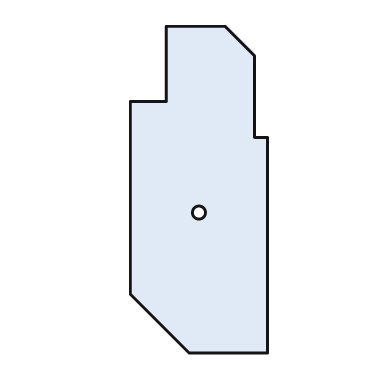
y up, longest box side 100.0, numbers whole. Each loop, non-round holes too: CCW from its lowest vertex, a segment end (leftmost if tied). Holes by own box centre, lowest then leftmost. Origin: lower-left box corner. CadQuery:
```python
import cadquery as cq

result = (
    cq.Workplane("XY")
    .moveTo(18.0, 0.0)
    .lineTo(42.0, 0.0)
    .lineTo(42.0, 66.0)
    .lineTo(38.0, 66.0)
    .lineTo(38.0, 91.0)
    .lineTo(29.0, 100.0)
    .lineTo(11.0, 100.0)
    .lineTo(11.0, 77.0)
    .lineTo(0.0, 77.0)
    .lineTo(0.0, 18.0)
    .close()
    .moveTo(21.0, 43.0)
    .circle(2.0)
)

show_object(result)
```